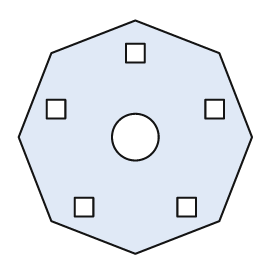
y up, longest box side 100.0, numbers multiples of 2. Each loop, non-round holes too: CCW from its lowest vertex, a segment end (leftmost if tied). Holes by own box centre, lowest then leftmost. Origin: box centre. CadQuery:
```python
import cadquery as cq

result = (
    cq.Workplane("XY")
    .moveTo(0.0, -50.0)
    .lineTo(36.0, -36.0)
    .lineTo(50.0, 0.0)
    .lineTo(36.0, 36.0)
    .lineTo(0.0, 50.0)
    .lineTo(-36.0, 36.0)
    .lineTo(-50.0, 0.0)
    .lineTo(-36.0, -36.0)
    .close()
    .moveTo(-26.0, -34.0)
    .lineTo(-18.0, -34.0)
    .lineTo(-18.0, -26.0)
    .lineTo(-26.0, -26.0)
    .close()
    .moveTo(18.0, -34.0)
    .lineTo(26.0, -34.0)
    .lineTo(26.0, -26.0)
    .lineTo(18.0, -26.0)
    .close()
    .moveTo(0.0, 0.0)
    .circle(10.0)
    .moveTo(-38.0, 8.0)
    .lineTo(-30.0, 8.0)
    .lineTo(-30.0, 16.0)
    .lineTo(-38.0, 16.0)
    .close()
    .moveTo(30.0, 8.0)
    .lineTo(38.0, 8.0)
    .lineTo(38.0, 16.0)
    .lineTo(30.0, 16.0)
    .close()
    .moveTo(-4.0, 32.0)
    .lineTo(4.0, 32.0)
    .lineTo(4.0, 40.0)
    .lineTo(-4.0, 40.0)
    .close()
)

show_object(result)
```